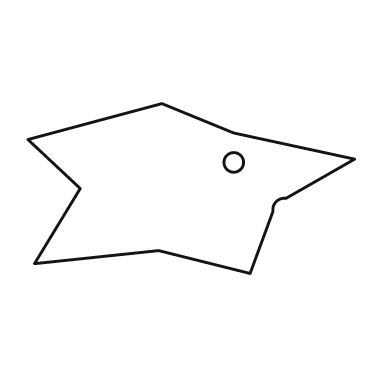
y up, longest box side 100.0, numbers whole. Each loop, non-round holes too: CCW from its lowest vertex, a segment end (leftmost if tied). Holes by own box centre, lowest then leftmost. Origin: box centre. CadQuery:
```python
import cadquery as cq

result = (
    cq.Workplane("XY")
    .moveTo(18.0, -26.0)
    .lineTo(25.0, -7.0)
    .threePointArc((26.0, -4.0), (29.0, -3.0))
    .lineTo(50.0, 9.0)
    .lineTo(13.0, 17.0)
    .lineTo(-9.0, 26.0)
    .lineTo(-50.0, 15.0)
    .lineTo(-34.0, 0.0)
    .lineTo(-48.0, -23.0)
    .lineTo(-10.0, -19.0)
    .close()
    .moveTo(13.0, 8.0)
    .circle(3.0)
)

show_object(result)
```